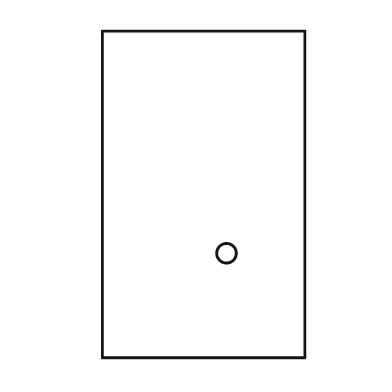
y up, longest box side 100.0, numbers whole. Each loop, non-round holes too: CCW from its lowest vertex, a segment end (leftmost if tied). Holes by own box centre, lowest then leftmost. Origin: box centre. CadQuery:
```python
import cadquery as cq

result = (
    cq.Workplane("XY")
    .moveTo(-31.0, -50.0)
    .lineTo(31.0, -50.0)
    .lineTo(31.0, 50.0)
    .lineTo(-31.0, 50.0)
    .close()
    .moveTo(7.0, -18.0)
    .circle(3.0)
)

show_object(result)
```